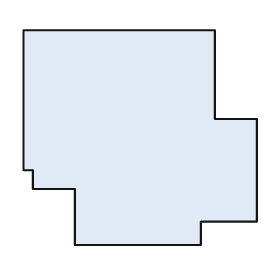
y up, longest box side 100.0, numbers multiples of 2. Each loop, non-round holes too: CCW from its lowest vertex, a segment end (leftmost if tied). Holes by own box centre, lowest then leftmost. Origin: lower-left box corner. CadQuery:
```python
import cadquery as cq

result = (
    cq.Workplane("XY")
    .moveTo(22.0, 0.0)
    .lineTo(76.0, 0.0)
    .lineTo(76.0, 10.0)
    .lineTo(100.0, 10.0)
    .lineTo(100.0, 54.0)
    .lineTo(82.0, 54.0)
    .lineTo(82.0, 92.0)
    .lineTo(0.0, 92.0)
    .lineTo(0.0, 32.0)
    .lineTo(4.0, 32.0)
    .lineTo(4.0, 24.0)
    .lineTo(22.0, 24.0)
    .close()
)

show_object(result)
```